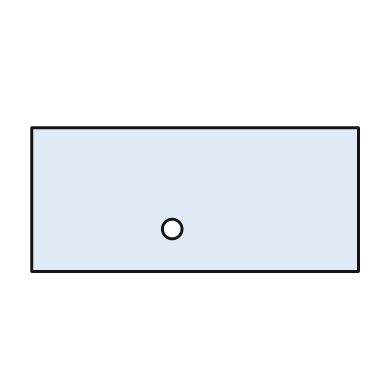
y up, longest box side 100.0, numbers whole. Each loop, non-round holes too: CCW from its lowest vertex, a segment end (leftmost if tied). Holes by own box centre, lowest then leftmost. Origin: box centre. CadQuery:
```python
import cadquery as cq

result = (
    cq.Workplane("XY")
    .moveTo(-50.0, -22.0)
    .lineTo(50.0, -22.0)
    .lineTo(50.0, 22.0)
    .lineTo(-50.0, 22.0)
    .close()
    .moveTo(-7.0, -9.0)
    .circle(3.0)
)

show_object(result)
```